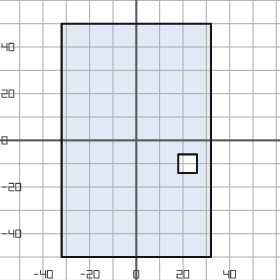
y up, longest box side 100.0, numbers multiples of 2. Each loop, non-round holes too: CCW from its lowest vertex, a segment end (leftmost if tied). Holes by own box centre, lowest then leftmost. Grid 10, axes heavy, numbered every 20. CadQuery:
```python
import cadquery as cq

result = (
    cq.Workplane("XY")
    .moveTo(-32.0, -50.0)
    .lineTo(32.0, -50.0)
    .lineTo(32.0, 50.0)
    .lineTo(-32.0, 50.0)
    .close()
    .moveTo(18.0, -14.0)
    .lineTo(26.0, -14.0)
    .lineTo(26.0, -6.0)
    .lineTo(18.0, -6.0)
    .close()
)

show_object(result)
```